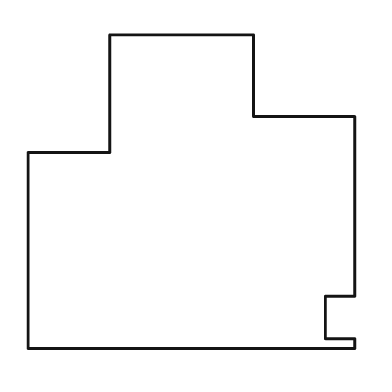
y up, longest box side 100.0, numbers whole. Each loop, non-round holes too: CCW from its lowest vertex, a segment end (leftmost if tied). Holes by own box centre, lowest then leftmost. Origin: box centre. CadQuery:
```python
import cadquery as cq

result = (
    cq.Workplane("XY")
    .moveTo(-50.0, -48.0)
    .lineTo(50.0, -48.0)
    .lineTo(50.0, -45.0)
    .lineTo(41.0, -45.0)
    .lineTo(41.0, -32.0)
    .lineTo(50.0, -32.0)
    .lineTo(50.0, 23.0)
    .lineTo(19.0, 23.0)
    .lineTo(19.0, 48.0)
    .lineTo(-25.0, 48.0)
    .lineTo(-25.0, 12.0)
    .lineTo(-50.0, 12.0)
    .close()
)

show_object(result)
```